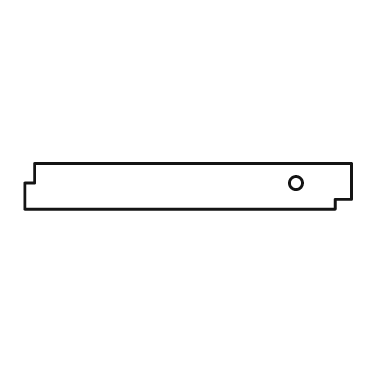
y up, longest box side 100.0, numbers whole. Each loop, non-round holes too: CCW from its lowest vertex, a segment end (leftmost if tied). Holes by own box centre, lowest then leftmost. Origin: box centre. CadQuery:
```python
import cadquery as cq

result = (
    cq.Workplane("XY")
    .moveTo(-50.0, -7.0)
    .lineTo(45.0, -7.0)
    .lineTo(45.0, -4.0)
    .lineTo(50.0, -4.0)
    .lineTo(50.0, 7.0)
    .lineTo(-47.0, 7.0)
    .lineTo(-47.0, 1.0)
    .lineTo(-50.0, 1.0)
    .close()
    .moveTo(33.0, 1.0)
    .circle(2.0)
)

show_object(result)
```